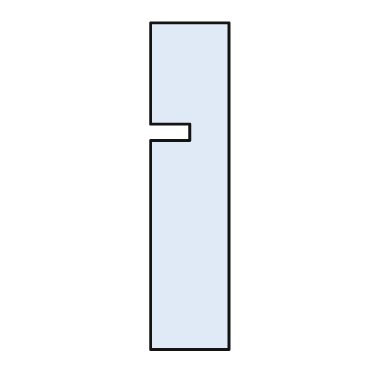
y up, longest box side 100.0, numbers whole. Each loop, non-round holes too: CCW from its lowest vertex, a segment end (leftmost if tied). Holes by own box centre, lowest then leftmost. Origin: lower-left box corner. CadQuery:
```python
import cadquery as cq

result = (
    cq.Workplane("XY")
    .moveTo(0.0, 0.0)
    .lineTo(24.0, 0.0)
    .lineTo(24.0, 100.0)
    .lineTo(0.0, 100.0)
    .lineTo(0.0, 69.0)
    .lineTo(12.0, 69.0)
    .lineTo(12.0, 64.0)
    .lineTo(0.0, 64.0)
    .close()
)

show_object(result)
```